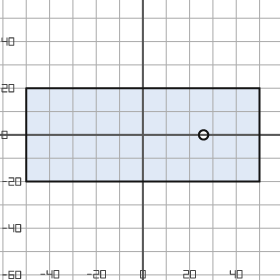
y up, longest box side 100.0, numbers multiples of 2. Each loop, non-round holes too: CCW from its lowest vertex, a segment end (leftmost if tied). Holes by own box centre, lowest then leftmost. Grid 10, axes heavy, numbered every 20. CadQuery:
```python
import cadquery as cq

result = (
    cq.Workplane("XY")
    .moveTo(-50.0, -20.0)
    .lineTo(50.0, -20.0)
    .lineTo(50.0, 20.0)
    .lineTo(-50.0, 20.0)
    .close()
    .moveTo(26.0, 0.0)
    .circle(2.0)
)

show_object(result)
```